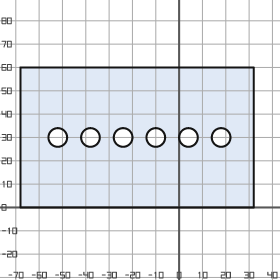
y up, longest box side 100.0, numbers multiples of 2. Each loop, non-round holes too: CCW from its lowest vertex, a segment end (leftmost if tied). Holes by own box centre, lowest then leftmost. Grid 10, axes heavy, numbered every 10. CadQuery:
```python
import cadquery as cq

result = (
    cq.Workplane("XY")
    .moveTo(-68.0, 0.0)
    .lineTo(32.0, 0.0)
    .lineTo(32.0, 60.0)
    .lineTo(-68.0, 60.0)
    .close()
    .moveTo(-52.0, 30.0)
    .circle(4.0)
    .moveTo(-38.0, 30.0)
    .circle(4.0)
    .moveTo(-24.0, 30.0)
    .circle(4.0)
    .moveTo(-10.0, 30.0)
    .circle(4.0)
    .moveTo(4.0, 30.0)
    .circle(4.0)
    .moveTo(18.0, 30.0)
    .circle(4.0)
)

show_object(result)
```